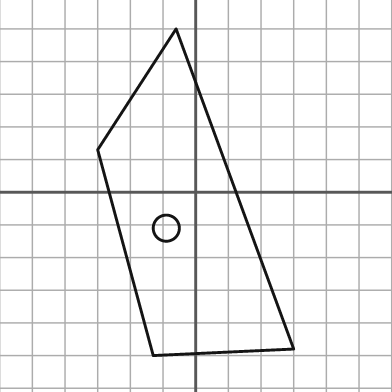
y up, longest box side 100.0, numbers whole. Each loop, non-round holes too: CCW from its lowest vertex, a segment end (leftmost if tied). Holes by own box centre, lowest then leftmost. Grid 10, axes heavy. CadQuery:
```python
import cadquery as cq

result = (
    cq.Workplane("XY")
    .moveTo(-13.0, -50.0)
    .lineTo(30.0, -48.0)
    .lineTo(-6.0, 50.0)
    .lineTo(-30.0, 13.0)
    .close()
    .moveTo(-9.0, -11.0)
    .circle(4.0)
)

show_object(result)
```